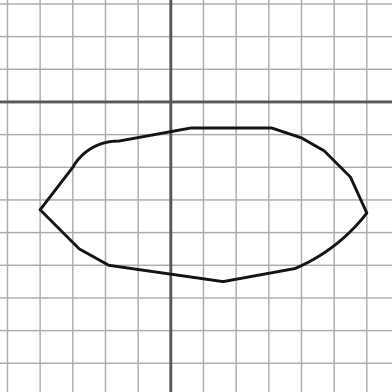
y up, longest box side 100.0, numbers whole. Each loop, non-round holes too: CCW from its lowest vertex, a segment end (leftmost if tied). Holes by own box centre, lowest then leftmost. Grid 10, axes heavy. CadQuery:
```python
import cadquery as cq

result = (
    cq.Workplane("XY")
    .moveTo(16.0, -55.0)
    .lineTo(38.0, -51.0)
    .threePointArc((50.0, -44.0), (60.0, -34.0))
    .lineTo(55.0, -23.0)
    .lineTo(47.0, -15.0)
    .lineTo(40.0, -11.0)
    .lineTo(31.0, -8.0)
    .lineTo(6.0, -8.0)
    .lineTo(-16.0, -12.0)
    .threePointArc((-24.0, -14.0), (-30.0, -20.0))
    .lineTo(-40.0, -33.0)
    .lineTo(-28.0, -45.0)
    .lineTo(-19.0, -50.0)
    .close()
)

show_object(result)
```